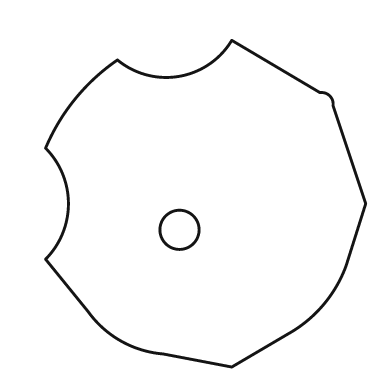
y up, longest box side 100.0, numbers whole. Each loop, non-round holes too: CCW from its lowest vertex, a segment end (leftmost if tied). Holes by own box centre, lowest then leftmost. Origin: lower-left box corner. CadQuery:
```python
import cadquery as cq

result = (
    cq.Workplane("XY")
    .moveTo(57.0, 0.0)
    .lineTo(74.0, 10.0)
    .threePointArc((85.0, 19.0), (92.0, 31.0))
    .lineTo(98.0, 50.0)
    .lineTo(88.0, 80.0)
    .threePointArc((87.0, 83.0), (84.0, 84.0))
    .lineTo(57.0, 100.0)
    .threePointArc((41.0, 89.0), (22.0, 94.0))
    .threePointArc((9.0, 82.0), (0.0, 67.0))
    .threePointArc((7.0, 50.0), (0.0, 33.0))
    .lineTo(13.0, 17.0)
    .threePointArc((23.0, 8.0), (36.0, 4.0))
    .close()
    .moveTo(41.0, 42.0)
    .circle(6.0)
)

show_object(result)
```